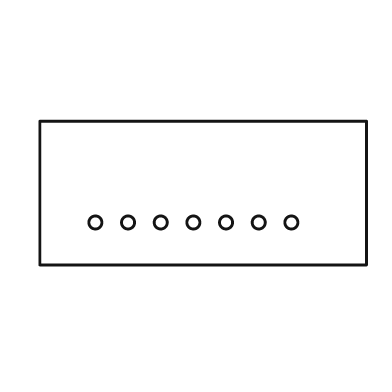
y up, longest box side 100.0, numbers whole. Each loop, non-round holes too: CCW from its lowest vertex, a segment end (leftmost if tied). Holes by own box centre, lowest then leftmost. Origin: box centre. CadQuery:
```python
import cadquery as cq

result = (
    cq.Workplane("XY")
    .moveTo(-50.0, -22.0)
    .lineTo(50.0, -22.0)
    .lineTo(50.0, 22.0)
    .lineTo(-50.0, 22.0)
    .close()
    .moveTo(-33.0, -9.0)
    .circle(2.0)
    .moveTo(-23.0, -9.0)
    .circle(2.0)
    .moveTo(-13.0, -9.0)
    .circle(2.0)
    .moveTo(-3.0, -9.0)
    .circle(2.0)
    .moveTo(7.0, -9.0)
    .circle(2.0)
    .moveTo(17.0, -9.0)
    .circle(2.0)
    .moveTo(27.0, -9.0)
    .circle(2.0)
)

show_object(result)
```